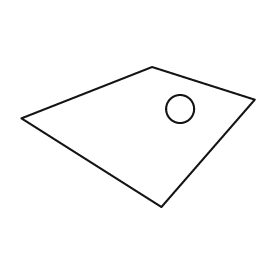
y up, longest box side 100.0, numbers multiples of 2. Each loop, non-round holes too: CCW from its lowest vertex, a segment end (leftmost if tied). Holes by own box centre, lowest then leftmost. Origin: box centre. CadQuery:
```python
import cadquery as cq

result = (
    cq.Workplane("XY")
    .moveTo(10.0, -30.0)
    .lineTo(50.0, 16.0)
    .lineTo(6.0, 30.0)
    .lineTo(-50.0, 8.0)
    .close()
    .moveTo(18.0, 12.0)
    .circle(6.0)
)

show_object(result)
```